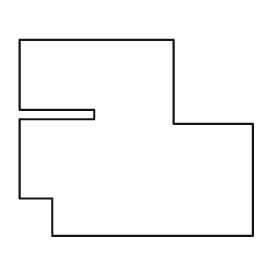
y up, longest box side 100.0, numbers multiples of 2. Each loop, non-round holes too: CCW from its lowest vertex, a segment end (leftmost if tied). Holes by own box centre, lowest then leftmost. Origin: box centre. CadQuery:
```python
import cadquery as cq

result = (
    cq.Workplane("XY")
    .moveTo(-36.0, -42.0)
    .lineTo(50.0, -42.0)
    .lineTo(50.0, 6.0)
    .lineTo(16.0, 6.0)
    .lineTo(16.0, 42.0)
    .lineTo(-50.0, 42.0)
    .lineTo(-50.0, 12.0)
    .lineTo(-18.0, 12.0)
    .lineTo(-18.0, 8.0)
    .lineTo(-50.0, 8.0)
    .lineTo(-50.0, -26.0)
    .lineTo(-36.0, -26.0)
    .close()
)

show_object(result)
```